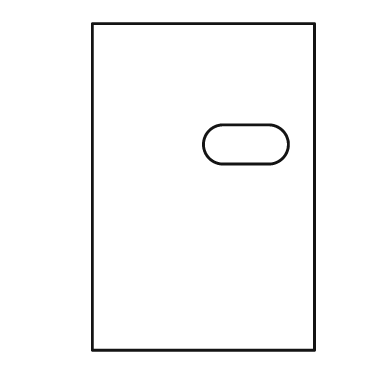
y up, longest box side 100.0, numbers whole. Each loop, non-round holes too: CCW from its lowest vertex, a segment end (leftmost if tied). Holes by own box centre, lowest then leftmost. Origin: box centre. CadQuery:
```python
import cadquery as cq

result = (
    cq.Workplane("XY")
    .moveTo(-34.0, -50.0)
    .lineTo(34.0, -50.0)
    .lineTo(34.0, 50.0)
    .lineTo(-34.0, 50.0)
    .close()
    .moveTo(6.0, 7.0)
    .lineTo(20.0, 7.0)
    .threePointArc((26.0, 13.0), (20.0, 19.0))
    .lineTo(6.0, 19.0)
    .threePointArc((0.0, 13.0), (6.0, 7.0))
    .close()
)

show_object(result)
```